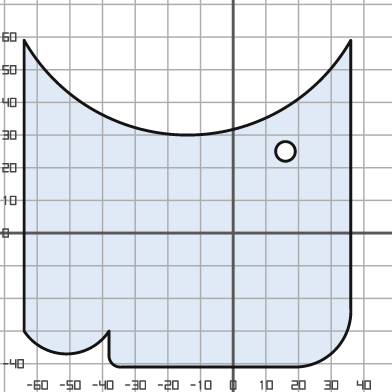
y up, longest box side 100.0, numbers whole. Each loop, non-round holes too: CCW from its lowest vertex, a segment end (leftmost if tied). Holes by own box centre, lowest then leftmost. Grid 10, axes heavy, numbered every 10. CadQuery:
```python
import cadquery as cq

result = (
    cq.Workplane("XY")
    .moveTo(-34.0, -41.0)
    .lineTo(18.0, -41.0)
    .threePointArc((31.0, -36.0), (36.0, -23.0))
    .lineTo(36.0, 59.0)
    .threePointArc((-14.0, 30.0), (-64.0, 59.0))
    .lineTo(-64.0, -30.0)
    .threePointArc((-51.0, -37.0), (-38.0, -30.0))
    .lineTo(-38.0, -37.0)
    .threePointArc((-37.0, -40.0), (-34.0, -41.0))
    .close()
    .moveTo(16.0, 25.0)
    .circle(3.0)
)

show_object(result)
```